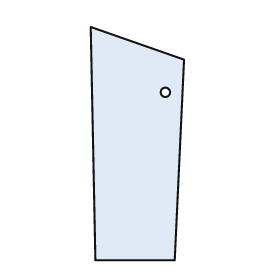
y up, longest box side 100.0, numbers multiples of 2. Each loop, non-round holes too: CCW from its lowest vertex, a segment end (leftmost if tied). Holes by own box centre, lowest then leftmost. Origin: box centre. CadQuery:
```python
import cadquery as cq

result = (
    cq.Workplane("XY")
    .moveTo(-18.0, -50.0)
    .lineTo(16.0, -50.0)
    .lineTo(20.0, 36.0)
    .lineTo(-20.0, 50.0)
    .close()
    .moveTo(12.0, 22.0)
    .circle(2.0)
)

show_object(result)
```